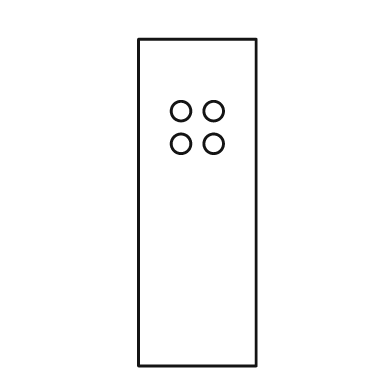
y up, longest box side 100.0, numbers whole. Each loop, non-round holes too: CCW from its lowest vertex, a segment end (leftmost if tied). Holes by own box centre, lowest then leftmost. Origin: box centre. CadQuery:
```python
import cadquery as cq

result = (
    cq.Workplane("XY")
    .moveTo(-18.0, -50.0)
    .lineTo(18.0, -50.0)
    .lineTo(18.0, 50.0)
    .lineTo(-18.0, 50.0)
    .close()
    .moveTo(-5.0, 18.0)
    .circle(3.0)
    .moveTo(5.0, 18.0)
    .circle(3.0)
    .moveTo(-5.0, 28.0)
    .circle(3.0)
    .moveTo(5.0, 28.0)
    .circle(3.0)
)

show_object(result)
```